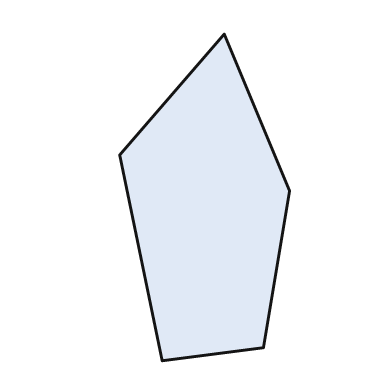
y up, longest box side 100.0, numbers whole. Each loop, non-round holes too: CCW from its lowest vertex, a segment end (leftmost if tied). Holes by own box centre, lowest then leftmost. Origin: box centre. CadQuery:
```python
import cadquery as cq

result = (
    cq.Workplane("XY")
    .moveTo(-13.0, -50.0)
    .lineTo(18.0, -46.0)
    .lineTo(26.0, 2.0)
    .lineTo(6.0, 50.0)
    .lineTo(-26.0, 13.0)
    .close()
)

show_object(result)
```